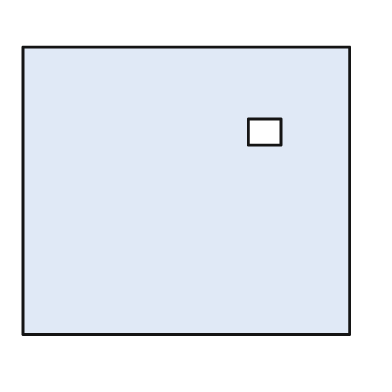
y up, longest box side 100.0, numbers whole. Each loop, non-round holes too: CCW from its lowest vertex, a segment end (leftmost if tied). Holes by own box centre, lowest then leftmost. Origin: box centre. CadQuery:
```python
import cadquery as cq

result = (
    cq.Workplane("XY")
    .moveTo(-50.0, -44.0)
    .lineTo(50.0, -44.0)
    .lineTo(50.0, 44.0)
    .lineTo(-50.0, 44.0)
    .close()
    .moveTo(19.0, 14.0)
    .lineTo(29.0, 14.0)
    .lineTo(29.0, 22.0)
    .lineTo(19.0, 22.0)
    .close()
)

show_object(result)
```